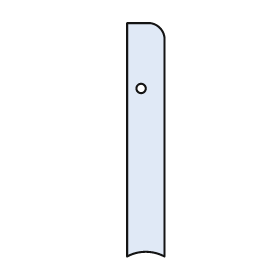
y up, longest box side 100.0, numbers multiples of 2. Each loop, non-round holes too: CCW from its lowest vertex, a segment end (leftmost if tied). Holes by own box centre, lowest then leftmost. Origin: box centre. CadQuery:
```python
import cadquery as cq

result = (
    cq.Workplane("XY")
    .moveTo(-8.0, -50.0)
    .threePointArc((0.0, -48.0), (8.0, -50.0))
    .lineTo(8.0, 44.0)
    .threePointArc((6.0, 48.0), (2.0, 50.0))
    .lineTo(-8.0, 50.0)
    .close()
    .moveTo(-2.0, 22.0)
    .circle(2.0)
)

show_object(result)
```